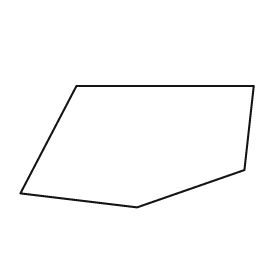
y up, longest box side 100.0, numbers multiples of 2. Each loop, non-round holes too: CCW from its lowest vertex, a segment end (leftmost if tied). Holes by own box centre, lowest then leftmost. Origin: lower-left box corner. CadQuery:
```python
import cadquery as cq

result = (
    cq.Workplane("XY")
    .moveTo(50.0, 0.0)
    .lineTo(96.0, 16.0)
    .lineTo(100.0, 52.0)
    .lineTo(24.0, 52.0)
    .lineTo(0.0, 6.0)
    .close()
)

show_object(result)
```